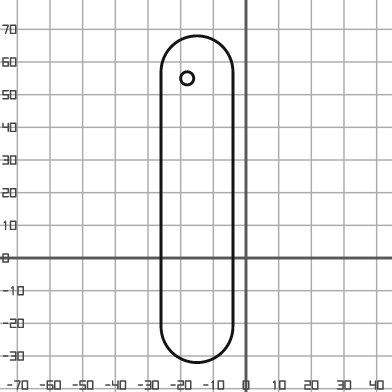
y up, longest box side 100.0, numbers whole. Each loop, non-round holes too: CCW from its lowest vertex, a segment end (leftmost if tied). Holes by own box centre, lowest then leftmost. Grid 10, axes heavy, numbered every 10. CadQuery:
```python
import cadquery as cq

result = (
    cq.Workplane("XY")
    .moveTo(-26.0, -21.0)
    .threePointArc((-15.0, -32.0), (-4.0, -21.0))
    .lineTo(-4.0, 57.0)
    .threePointArc((-15.0, 68.0), (-26.0, 57.0))
    .close()
    .moveTo(-18.0, 55.0)
    .circle(2.0)
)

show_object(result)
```